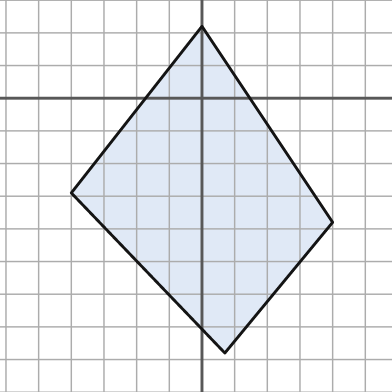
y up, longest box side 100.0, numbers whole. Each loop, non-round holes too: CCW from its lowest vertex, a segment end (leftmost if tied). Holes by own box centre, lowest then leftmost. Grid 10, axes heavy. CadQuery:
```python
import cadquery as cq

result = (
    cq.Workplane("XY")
    .moveTo(7.0, -78.0)
    .lineTo(40.0, -38.0)
    .lineTo(0.0, 22.0)
    .lineTo(-40.0, -29.0)
    .close()
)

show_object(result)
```